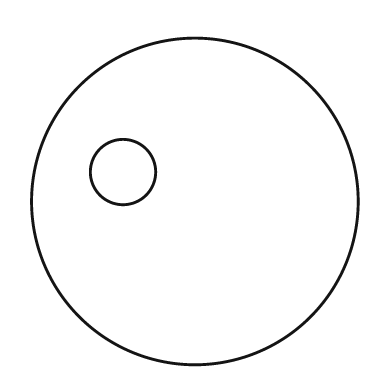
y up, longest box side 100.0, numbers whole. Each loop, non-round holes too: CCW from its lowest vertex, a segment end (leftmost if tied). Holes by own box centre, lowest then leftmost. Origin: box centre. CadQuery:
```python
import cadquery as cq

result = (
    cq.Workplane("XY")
    .moveTo(0.0, 0.0)
    .circle(50.0)
    .moveTo(-22.0, 9.0)
    .circle(10.0)
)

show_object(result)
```